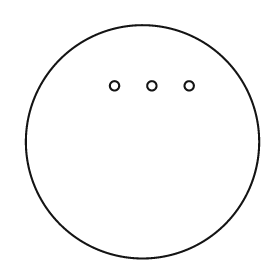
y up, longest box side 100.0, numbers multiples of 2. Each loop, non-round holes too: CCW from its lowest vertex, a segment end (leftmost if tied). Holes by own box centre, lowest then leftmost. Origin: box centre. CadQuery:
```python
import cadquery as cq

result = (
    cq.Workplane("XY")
    .moveTo(0.0, 0.0)
    .circle(50.0)
    .moveTo(-12.0, 24.0)
    .circle(2.0)
    .moveTo(4.0, 24.0)
    .circle(2.0)
    .moveTo(20.0, 24.0)
    .circle(2.0)
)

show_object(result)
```